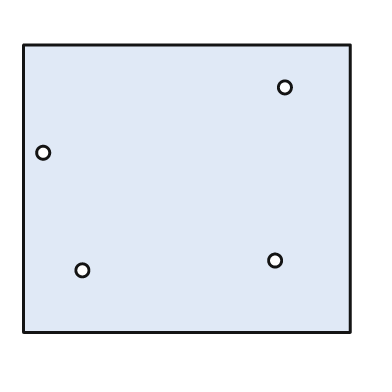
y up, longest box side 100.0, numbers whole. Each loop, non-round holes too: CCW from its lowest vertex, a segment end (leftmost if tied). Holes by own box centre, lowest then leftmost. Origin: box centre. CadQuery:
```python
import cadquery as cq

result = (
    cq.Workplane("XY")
    .moveTo(-50.0, -44.0)
    .lineTo(50.0, -44.0)
    .lineTo(50.0, 44.0)
    .lineTo(-50.0, 44.0)
    .close()
    .moveTo(-32.0, -25.0)
    .circle(2.0)
    .moveTo(27.0, -22.0)
    .circle(2.0)
    .moveTo(-44.0, 11.0)
    .circle(2.0)
    .moveTo(30.0, 31.0)
    .circle(2.0)
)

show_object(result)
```